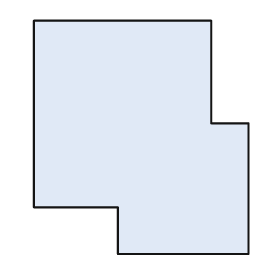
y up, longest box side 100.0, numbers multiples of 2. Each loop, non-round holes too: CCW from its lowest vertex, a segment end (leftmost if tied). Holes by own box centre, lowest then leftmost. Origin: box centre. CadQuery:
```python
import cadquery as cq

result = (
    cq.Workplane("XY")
    .moveTo(-10.0, -50.0)
    .lineTo(46.0, -50.0)
    .lineTo(46.0, 6.0)
    .lineTo(30.0, 6.0)
    .lineTo(30.0, 50.0)
    .lineTo(-46.0, 50.0)
    .lineTo(-46.0, -30.0)
    .lineTo(-10.0, -30.0)
    .close()
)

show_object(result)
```